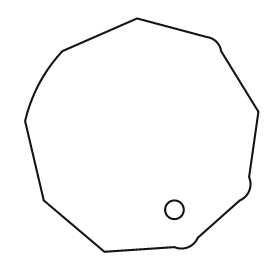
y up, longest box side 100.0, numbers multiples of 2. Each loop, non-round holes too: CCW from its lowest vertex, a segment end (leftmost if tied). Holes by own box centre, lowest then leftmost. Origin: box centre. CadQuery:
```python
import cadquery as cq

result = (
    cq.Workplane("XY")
    .moveTo(-16.0, -50.0)
    .lineTo(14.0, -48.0)
    .threePointArc((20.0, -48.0), (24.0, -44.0))
    .lineTo(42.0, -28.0)
    .threePointArc((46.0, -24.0), (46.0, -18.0))
    .lineTo(50.0, 10.0)
    .lineTo(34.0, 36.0)
    .threePointArc((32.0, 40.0), (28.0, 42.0))
    .lineTo(-2.0, 50.0)
    .lineTo(-34.0, 36.0)
    .threePointArc((-44.0, 22.0), (-50.0, 6.0))
    .lineTo(-42.0, -28.0)
    .close()
    .moveTo(14.0, -32.0)
    .circle(4.0)
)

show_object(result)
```